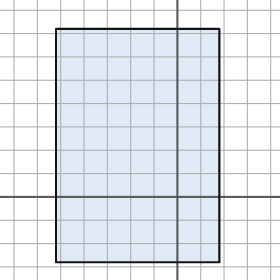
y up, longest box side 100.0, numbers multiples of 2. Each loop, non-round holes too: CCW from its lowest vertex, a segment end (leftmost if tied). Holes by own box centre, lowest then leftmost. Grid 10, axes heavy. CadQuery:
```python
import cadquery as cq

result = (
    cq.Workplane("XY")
    .moveTo(-52.0, -28.0)
    .lineTo(18.0, -28.0)
    .lineTo(18.0, 72.0)
    .lineTo(-52.0, 72.0)
    .close()
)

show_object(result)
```